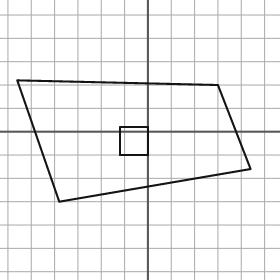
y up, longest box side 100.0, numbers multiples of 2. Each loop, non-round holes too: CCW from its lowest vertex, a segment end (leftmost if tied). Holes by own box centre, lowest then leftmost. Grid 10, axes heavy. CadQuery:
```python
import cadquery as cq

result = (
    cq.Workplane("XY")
    .moveTo(-38.0, -30.0)
    .lineTo(44.0, -16.0)
    .lineTo(30.0, 20.0)
    .lineTo(-56.0, 22.0)
    .close()
    .moveTo(-12.0, -10.0)
    .lineTo(0.0, -10.0)
    .lineTo(0.0, 2.0)
    .lineTo(-12.0, 2.0)
    .close()
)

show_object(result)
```